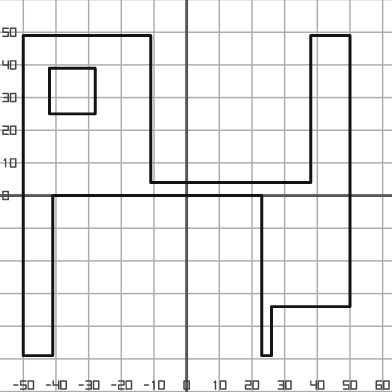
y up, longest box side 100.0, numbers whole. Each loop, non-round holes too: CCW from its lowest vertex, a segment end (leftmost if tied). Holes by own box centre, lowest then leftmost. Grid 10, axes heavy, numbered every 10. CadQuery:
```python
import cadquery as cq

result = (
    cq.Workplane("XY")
    .moveTo(-50.0, -49.0)
    .lineTo(-41.0, -49.0)
    .lineTo(-41.0, 0.0)
    .lineTo(23.0, 0.0)
    .lineTo(23.0, -49.0)
    .lineTo(26.0, -49.0)
    .lineTo(26.0, -34.0)
    .lineTo(50.0, -34.0)
    .lineTo(50.0, 49.0)
    .lineTo(38.0, 49.0)
    .lineTo(38.0, 4.0)
    .lineTo(-11.0, 4.0)
    .lineTo(-11.0, 49.0)
    .lineTo(-50.0, 49.0)
    .close()
    .moveTo(-42.0, 25.0)
    .lineTo(-28.0, 25.0)
    .lineTo(-28.0, 39.0)
    .lineTo(-42.0, 39.0)
    .close()
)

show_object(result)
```